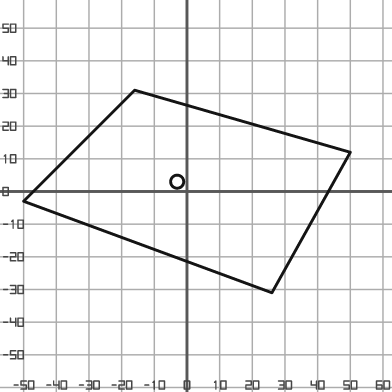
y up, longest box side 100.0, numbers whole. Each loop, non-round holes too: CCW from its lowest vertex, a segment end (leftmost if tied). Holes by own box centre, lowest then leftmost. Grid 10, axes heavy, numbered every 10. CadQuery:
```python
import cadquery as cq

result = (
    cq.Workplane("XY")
    .moveTo(26.0, -31.0)
    .lineTo(50.0, 12.0)
    .lineTo(-16.0, 31.0)
    .lineTo(-50.0, -3.0)
    .close()
    .moveTo(-3.0, 3.0)
    .circle(2.0)
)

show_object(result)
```